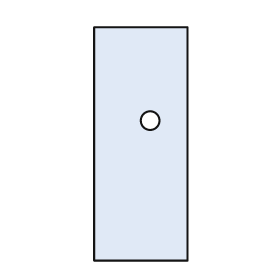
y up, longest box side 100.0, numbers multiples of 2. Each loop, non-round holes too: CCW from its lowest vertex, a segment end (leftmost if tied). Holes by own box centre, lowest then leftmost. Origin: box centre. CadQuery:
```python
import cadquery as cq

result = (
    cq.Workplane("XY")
    .moveTo(-20.0, -50.0)
    .lineTo(20.0, -50.0)
    .lineTo(20.0, 50.0)
    .lineTo(-20.0, 50.0)
    .close()
    .moveTo(4.0, 10.0)
    .circle(4.0)
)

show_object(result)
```